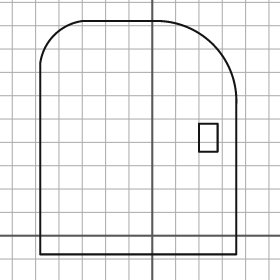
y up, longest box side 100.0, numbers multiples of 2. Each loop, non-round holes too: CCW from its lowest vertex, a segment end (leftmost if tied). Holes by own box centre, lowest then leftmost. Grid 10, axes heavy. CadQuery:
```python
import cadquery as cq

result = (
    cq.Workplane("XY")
    .moveTo(-48.0, -8.0)
    .lineTo(36.0, -8.0)
    .lineTo(36.0, 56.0)
    .threePointArc((26.0, 82.0), (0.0, 92.0))
    .lineTo(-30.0, 92.0)
    .threePointArc((-42.0, 86.0), (-48.0, 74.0))
    .close()
    .moveTo(20.0, 36.0)
    .lineTo(28.0, 36.0)
    .lineTo(28.0, 48.0)
    .lineTo(20.0, 48.0)
    .close()
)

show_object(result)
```